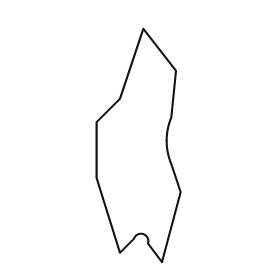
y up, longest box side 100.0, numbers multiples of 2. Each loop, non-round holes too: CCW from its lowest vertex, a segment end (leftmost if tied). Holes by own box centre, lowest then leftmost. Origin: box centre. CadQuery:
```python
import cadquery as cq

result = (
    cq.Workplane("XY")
    .moveTo(10.0, -50.0)
    .lineTo(18.0, -20.0)
    .lineTo(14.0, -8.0)
    .threePointArc((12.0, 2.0), (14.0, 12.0))
    .lineTo(16.0, 32.0)
    .lineTo(2.0, 50.0)
    .lineTo(-8.0, 20.0)
    .lineTo(-18.0, 10.0)
    .lineTo(-18.0, -14.0)
    .lineTo(-8.0, -46.0)
    .lineTo(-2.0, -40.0)
    .threePointArc((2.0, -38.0), (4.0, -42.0))
    .close()
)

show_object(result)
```